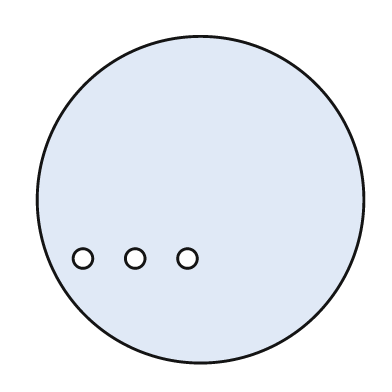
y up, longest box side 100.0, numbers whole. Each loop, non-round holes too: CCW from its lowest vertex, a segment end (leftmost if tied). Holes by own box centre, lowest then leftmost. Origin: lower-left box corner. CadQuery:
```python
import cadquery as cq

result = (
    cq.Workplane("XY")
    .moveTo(50.0, 50.0)
    .circle(50.0)
    .moveTo(14.0, 32.0)
    .circle(3.0)
    .moveTo(30.0, 32.0)
    .circle(3.0)
    .moveTo(46.0, 32.0)
    .circle(3.0)
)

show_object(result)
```